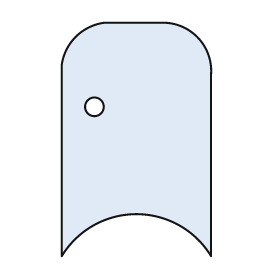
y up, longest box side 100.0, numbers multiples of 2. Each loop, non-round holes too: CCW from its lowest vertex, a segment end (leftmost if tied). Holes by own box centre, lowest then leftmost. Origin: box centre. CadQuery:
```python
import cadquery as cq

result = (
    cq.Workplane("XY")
    .moveTo(-32.0, -50.0)
    .threePointArc((0.0, -32.0), (32.0, -50.0))
    .lineTo(32.0, 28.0)
    .threePointArc((26.0, 44.0), (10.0, 50.0))
    .lineTo(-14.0, 50.0)
    .threePointArc((-26.0, 44.0), (-32.0, 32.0))
    .close()
    .moveTo(-18.0, 14.0)
    .circle(4.0)
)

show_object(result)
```